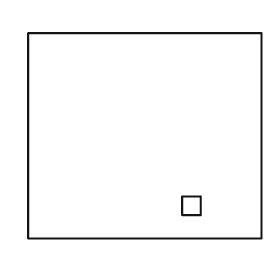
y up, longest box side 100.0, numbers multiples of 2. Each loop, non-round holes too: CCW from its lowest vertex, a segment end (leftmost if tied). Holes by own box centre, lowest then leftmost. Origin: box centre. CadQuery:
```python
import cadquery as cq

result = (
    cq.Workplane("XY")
    .moveTo(-50.0, -44.0)
    .lineTo(50.0, -44.0)
    .lineTo(50.0, 44.0)
    .lineTo(-50.0, 44.0)
    .close()
    .moveTo(16.0, -34.0)
    .lineTo(24.0, -34.0)
    .lineTo(24.0, -26.0)
    .lineTo(16.0, -26.0)
    .close()
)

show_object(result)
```